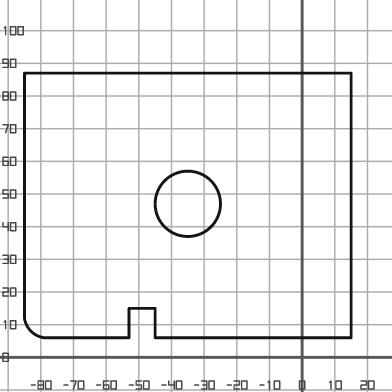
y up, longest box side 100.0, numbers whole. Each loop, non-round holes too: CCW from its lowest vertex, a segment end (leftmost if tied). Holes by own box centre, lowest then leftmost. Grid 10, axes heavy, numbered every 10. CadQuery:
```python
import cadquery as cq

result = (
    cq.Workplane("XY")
    .moveTo(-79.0, 6.0)
    .lineTo(-53.0, 6.0)
    .lineTo(-53.0, 15.0)
    .lineTo(-45.0, 15.0)
    .lineTo(-45.0, 6.0)
    .lineTo(15.0, 6.0)
    .lineTo(15.0, 87.0)
    .lineTo(-85.0, 87.0)
    .lineTo(-85.0, 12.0)
    .threePointArc((-83.0, 8.0), (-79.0, 6.0))
    .close()
    .moveTo(-35.0, 47.0)
    .circle(10.0)
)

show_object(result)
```